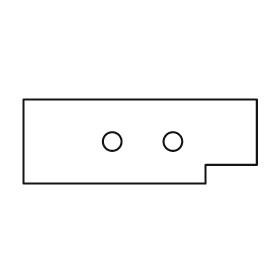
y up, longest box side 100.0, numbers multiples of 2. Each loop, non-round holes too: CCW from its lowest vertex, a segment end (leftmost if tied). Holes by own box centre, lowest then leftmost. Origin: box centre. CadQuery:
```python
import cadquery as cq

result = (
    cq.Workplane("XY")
    .moveTo(-50.0, -18.0)
    .lineTo(28.0, -18.0)
    .lineTo(28.0, -10.0)
    .lineTo(50.0, -10.0)
    .lineTo(50.0, 18.0)
    .lineTo(-50.0, 18.0)
    .close()
    .moveTo(-12.0, 0.0)
    .circle(4.0)
    .moveTo(14.0, 0.0)
    .circle(4.0)
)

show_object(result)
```